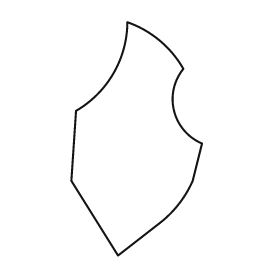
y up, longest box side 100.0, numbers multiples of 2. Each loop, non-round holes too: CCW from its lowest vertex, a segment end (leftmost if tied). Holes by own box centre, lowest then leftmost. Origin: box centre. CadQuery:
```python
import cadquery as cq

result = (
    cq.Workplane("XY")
    .moveTo(-8.0, -50.0)
    .lineTo(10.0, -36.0)
    .threePointArc((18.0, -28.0), (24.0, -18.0))
    .lineTo(28.0, -2.0)
    .threePointArc((16.0, 12.0), (20.0, 30.0))
    .threePointArc((10.0, 42.0), (-4.0, 50.0))
    .threePointArc((-10.0, 28.0), (-26.0, 12.0))
    .lineTo(-28.0, -18.0)
    .close()
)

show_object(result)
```